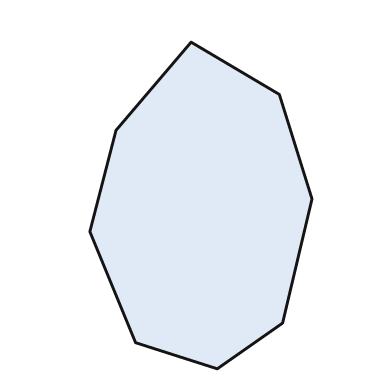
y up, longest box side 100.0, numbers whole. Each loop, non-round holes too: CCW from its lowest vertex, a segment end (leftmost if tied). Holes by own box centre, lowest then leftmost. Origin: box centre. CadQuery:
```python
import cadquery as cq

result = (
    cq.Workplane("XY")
    .moveTo(5.0, -50.0)
    .lineTo(25.0, -36.0)
    .lineTo(34.0, 2.0)
    .lineTo(24.0, 34.0)
    .lineTo(-3.0, 50.0)
    .lineTo(-26.0, 23.0)
    .lineTo(-34.0, -8.0)
    .lineTo(-20.0, -42.0)
    .close()
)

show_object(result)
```